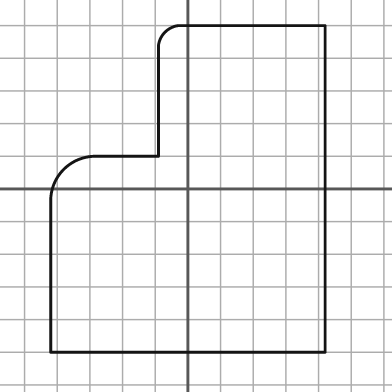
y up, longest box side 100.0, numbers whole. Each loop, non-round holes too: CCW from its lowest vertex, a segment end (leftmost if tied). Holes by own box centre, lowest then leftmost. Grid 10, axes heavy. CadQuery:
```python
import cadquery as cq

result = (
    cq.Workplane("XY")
    .moveTo(-42.0, -50.0)
    .lineTo(42.0, -50.0)
    .lineTo(42.0, 50.0)
    .lineTo(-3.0, 50.0)
    .threePointArc((-7.0, 48.0), (-9.0, 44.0))
    .lineTo(-9.0, 10.0)
    .lineTo(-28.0, 10.0)
    .threePointArc((-38.0, 6.0), (-42.0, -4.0))
    .close()
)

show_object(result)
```